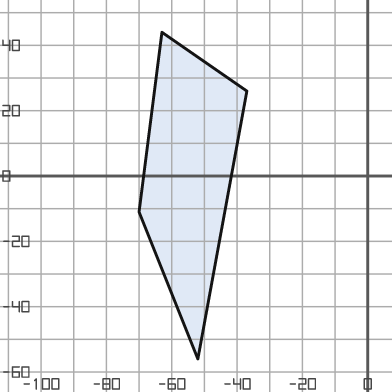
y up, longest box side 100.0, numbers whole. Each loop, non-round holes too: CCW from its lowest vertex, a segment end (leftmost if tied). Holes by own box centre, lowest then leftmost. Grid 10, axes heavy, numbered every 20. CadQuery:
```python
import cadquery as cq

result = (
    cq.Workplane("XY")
    .moveTo(-52.0, -56.0)
    .lineTo(-37.0, 26.0)
    .lineTo(-63.0, 44.0)
    .lineTo(-70.0, -11.0)
    .close()
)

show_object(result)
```